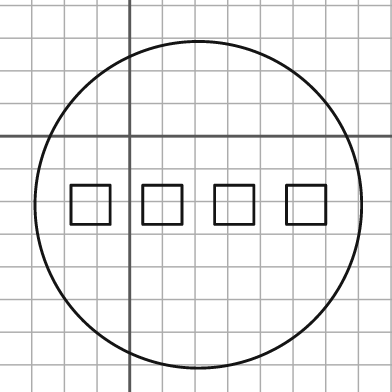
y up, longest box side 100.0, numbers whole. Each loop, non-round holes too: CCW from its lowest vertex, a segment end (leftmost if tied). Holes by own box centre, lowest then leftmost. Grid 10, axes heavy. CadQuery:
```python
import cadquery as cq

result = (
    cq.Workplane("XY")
    .moveTo(21.0, -21.0)
    .circle(50.0)
    .moveTo(-18.0, -27.0)
    .lineTo(-6.0, -27.0)
    .lineTo(-6.0, -15.0)
    .lineTo(-18.0, -15.0)
    .close()
    .moveTo(4.0, -27.0)
    .lineTo(16.0, -27.0)
    .lineTo(16.0, -15.0)
    .lineTo(4.0, -15.0)
    .close()
    .moveTo(26.0, -27.0)
    .lineTo(38.0, -27.0)
    .lineTo(38.0, -15.0)
    .lineTo(26.0, -15.0)
    .close()
    .moveTo(48.0, -27.0)
    .lineTo(60.0, -27.0)
    .lineTo(60.0, -15.0)
    .lineTo(48.0, -15.0)
    .close()
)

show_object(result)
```